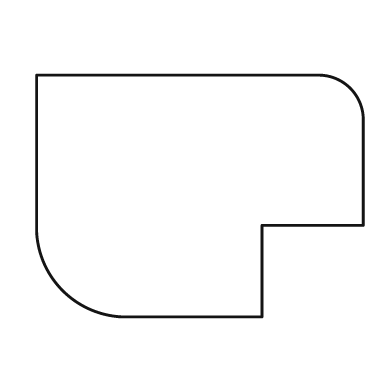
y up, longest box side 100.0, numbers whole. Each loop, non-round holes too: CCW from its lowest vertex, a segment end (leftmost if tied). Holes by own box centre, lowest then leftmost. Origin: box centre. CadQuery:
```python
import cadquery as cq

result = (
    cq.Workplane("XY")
    .moveTo(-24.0, -37.0)
    .lineTo(19.0, -37.0)
    .lineTo(19.0, -9.0)
    .lineTo(50.0, -9.0)
    .lineTo(50.0, 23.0)
    .threePointArc((46.0, 33.0), (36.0, 37.0))
    .lineTo(-50.0, 37.0)
    .lineTo(-50.0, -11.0)
    .threePointArc((-42.0, -29.0), (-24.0, -37.0))
    .close()
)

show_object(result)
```